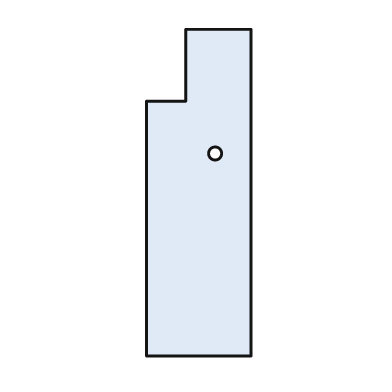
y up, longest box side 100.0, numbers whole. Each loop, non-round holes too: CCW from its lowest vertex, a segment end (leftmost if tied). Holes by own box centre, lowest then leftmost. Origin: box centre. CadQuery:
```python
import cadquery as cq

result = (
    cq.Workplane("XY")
    .moveTo(-16.0, -50.0)
    .lineTo(16.0, -50.0)
    .lineTo(16.0, 50.0)
    .lineTo(-4.0, 50.0)
    .lineTo(-4.0, 28.0)
    .lineTo(-16.0, 28.0)
    .close()
    .moveTo(5.0, 12.0)
    .circle(2.0)
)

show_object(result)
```